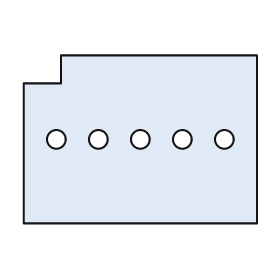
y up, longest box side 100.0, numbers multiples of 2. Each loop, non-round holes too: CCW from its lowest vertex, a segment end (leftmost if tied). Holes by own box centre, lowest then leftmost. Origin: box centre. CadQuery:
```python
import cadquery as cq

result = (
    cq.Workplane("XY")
    .moveTo(-50.0, -36.0)
    .lineTo(50.0, -36.0)
    .lineTo(50.0, 36.0)
    .lineTo(-34.0, 36.0)
    .lineTo(-34.0, 24.0)
    .lineTo(-50.0, 24.0)
    .close()
    .moveTo(-36.0, 0.0)
    .circle(4.0)
    .moveTo(-18.0, 0.0)
    .circle(4.0)
    .moveTo(0.0, 0.0)
    .circle(4.0)
    .moveTo(18.0, 0.0)
    .circle(4.0)
    .moveTo(36.0, 0.0)
    .circle(4.0)
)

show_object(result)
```